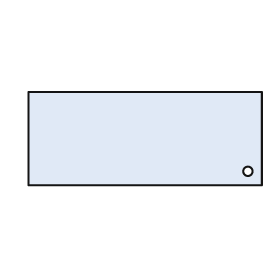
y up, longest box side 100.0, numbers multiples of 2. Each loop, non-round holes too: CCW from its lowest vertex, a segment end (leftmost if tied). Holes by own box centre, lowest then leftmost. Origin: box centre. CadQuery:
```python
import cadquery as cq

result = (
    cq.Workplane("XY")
    .moveTo(-50.0, -20.0)
    .lineTo(50.0, -20.0)
    .lineTo(50.0, 20.0)
    .lineTo(-50.0, 20.0)
    .close()
    .moveTo(44.0, -14.0)
    .circle(2.0)
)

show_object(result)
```